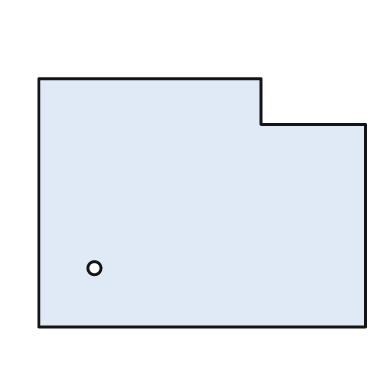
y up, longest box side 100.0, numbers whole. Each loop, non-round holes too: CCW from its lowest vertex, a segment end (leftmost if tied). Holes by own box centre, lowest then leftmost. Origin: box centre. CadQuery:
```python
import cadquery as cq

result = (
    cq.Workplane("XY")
    .moveTo(-50.0, -38.0)
    .lineTo(50.0, -38.0)
    .lineTo(50.0, 24.0)
    .lineTo(18.0, 24.0)
    .lineTo(18.0, 38.0)
    .lineTo(-50.0, 38.0)
    .close()
    .moveTo(-33.0, -20.0)
    .circle(2.0)
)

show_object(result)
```